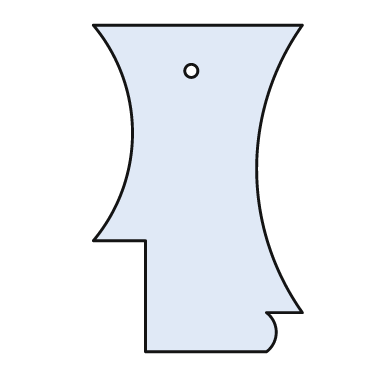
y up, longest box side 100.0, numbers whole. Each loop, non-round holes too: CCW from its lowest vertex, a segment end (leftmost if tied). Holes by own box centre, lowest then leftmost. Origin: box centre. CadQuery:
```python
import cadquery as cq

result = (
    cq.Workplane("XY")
    .moveTo(-16.0, -50.0)
    .lineTo(21.0, -50.0)
    .threePointArc((24.0, -44.0), (21.0, -38.0))
    .lineTo(32.0, -38.0)
    .threePointArc((18.0, 6.0), (32.0, 50.0))
    .lineTo(-32.0, 50.0)
    .threePointArc((-20.0, 17.0), (-32.0, -16.0))
    .lineTo(-16.0, -16.0)
    .close()
    .moveTo(-2.0, 36.0)
    .circle(2.0)
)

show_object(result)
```